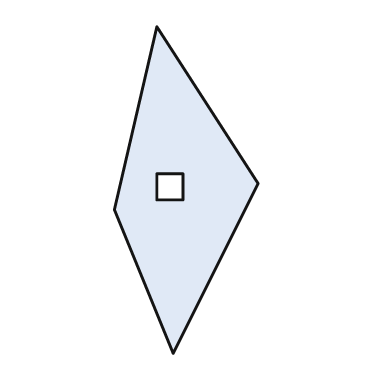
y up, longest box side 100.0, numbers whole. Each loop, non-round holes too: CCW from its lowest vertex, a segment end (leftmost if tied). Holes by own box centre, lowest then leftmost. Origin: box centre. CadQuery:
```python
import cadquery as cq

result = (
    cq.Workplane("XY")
    .moveTo(-4.0, -50.0)
    .lineTo(22.0, 2.0)
    .lineTo(-9.0, 50.0)
    .lineTo(-22.0, -6.0)
    .close()
    .moveTo(-9.0, -3.0)
    .lineTo(-1.0, -3.0)
    .lineTo(-1.0, 5.0)
    .lineTo(-9.0, 5.0)
    .close()
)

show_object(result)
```